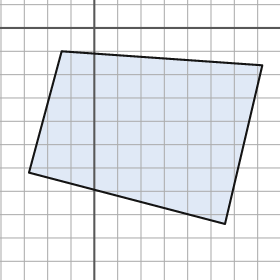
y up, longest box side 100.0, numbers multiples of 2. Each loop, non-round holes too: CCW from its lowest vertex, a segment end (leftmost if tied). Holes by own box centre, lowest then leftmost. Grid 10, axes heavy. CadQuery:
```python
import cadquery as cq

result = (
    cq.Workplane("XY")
    .moveTo(56.0, -84.0)
    .lineTo(72.0, -16.0)
    .lineTo(-14.0, -10.0)
    .lineTo(-28.0, -62.0)
    .close()
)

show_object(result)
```